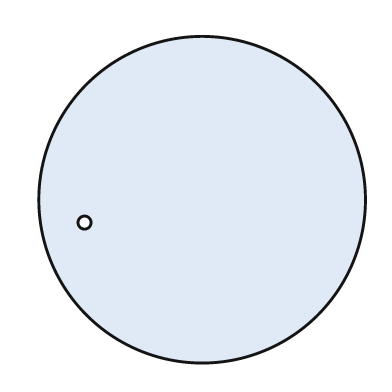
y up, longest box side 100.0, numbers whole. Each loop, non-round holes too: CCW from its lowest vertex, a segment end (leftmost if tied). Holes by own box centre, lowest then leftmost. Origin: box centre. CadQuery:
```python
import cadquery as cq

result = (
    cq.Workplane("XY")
    .moveTo(0.0, 0.0)
    .circle(50.0)
    .moveTo(-36.0, -7.0)
    .circle(2.0)
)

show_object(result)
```